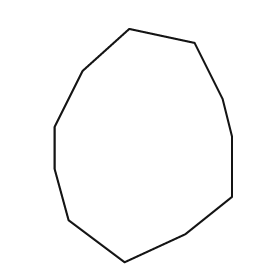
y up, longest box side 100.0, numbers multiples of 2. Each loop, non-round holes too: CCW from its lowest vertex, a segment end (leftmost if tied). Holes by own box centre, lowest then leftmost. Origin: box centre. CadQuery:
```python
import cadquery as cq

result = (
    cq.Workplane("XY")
    .moveTo(-8.0, -50.0)
    .lineTo(18.0, -38.0)
    .lineTo(38.0, -22.0)
    .lineTo(38.0, 4.0)
    .lineTo(34.0, 20.0)
    .lineTo(22.0, 44.0)
    .lineTo(-6.0, 50.0)
    .lineTo(-26.0, 32.0)
    .lineTo(-38.0, 8.0)
    .lineTo(-38.0, -10.0)
    .lineTo(-32.0, -32.0)
    .close()
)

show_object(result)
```